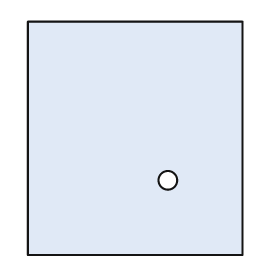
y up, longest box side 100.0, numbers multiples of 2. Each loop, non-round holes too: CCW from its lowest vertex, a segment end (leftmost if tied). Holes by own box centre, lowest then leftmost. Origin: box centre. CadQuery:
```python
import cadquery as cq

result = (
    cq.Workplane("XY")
    .moveTo(-46.0, -50.0)
    .lineTo(46.0, -50.0)
    .lineTo(46.0, 50.0)
    .lineTo(-46.0, 50.0)
    .close()
    .moveTo(14.0, -18.0)
    .circle(4.0)
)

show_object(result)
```